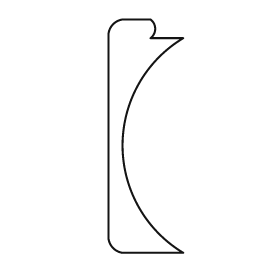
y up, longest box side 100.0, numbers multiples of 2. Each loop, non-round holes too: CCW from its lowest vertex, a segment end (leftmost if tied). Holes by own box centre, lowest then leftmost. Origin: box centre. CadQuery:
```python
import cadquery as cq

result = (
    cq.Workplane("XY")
    .moveTo(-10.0, -50.0)
    .lineTo(16.0, -50.0)
    .threePointArc((-10.0, -4.0), (16.0, 42.0))
    .lineTo(2.0, 42.0)
    .threePointArc((4.0, 46.0), (2.0, 50.0))
    .lineTo(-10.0, 50.0)
    .threePointArc((-14.0, 48.0), (-16.0, 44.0))
    .lineTo(-16.0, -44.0)
    .threePointArc((-14.0, -48.0), (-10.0, -50.0))
    .close()
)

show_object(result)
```